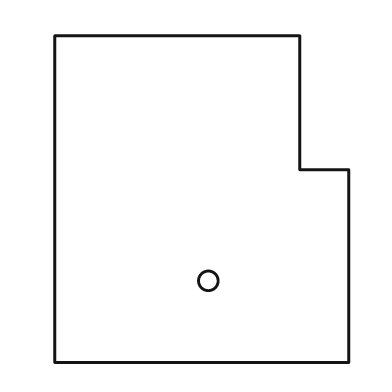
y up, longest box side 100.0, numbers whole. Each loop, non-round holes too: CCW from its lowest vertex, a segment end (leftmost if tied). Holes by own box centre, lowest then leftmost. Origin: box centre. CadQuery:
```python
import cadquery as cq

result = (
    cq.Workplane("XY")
    .moveTo(-45.0, -50.0)
    .lineTo(45.0, -50.0)
    .lineTo(45.0, 9.0)
    .lineTo(30.0, 9.0)
    .lineTo(30.0, 50.0)
    .lineTo(-45.0, 50.0)
    .close()
    .moveTo(2.0, -25.0)
    .circle(3.0)
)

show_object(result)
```